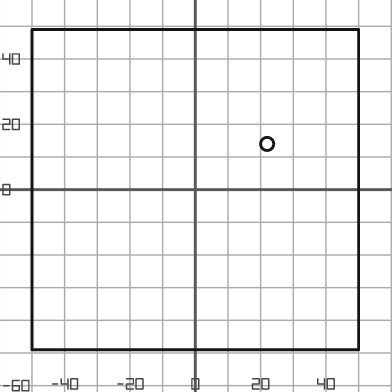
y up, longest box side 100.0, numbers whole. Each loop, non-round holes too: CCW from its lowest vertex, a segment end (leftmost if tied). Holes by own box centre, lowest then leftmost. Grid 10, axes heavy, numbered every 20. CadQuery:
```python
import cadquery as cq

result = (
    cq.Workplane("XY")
    .moveTo(-50.0, -49.0)
    .lineTo(50.0, -49.0)
    .lineTo(50.0, 49.0)
    .lineTo(-50.0, 49.0)
    .close()
    .moveTo(22.0, 14.0)
    .circle(2.0)
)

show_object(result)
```